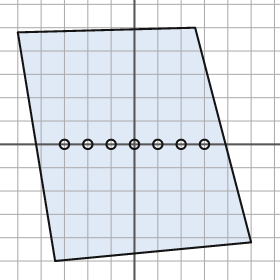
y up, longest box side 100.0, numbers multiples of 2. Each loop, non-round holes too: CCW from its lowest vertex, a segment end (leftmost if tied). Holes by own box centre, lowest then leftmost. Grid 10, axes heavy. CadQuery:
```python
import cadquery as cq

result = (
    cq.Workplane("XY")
    .moveTo(-34.0, -50.0)
    .lineTo(50.0, -42.0)
    .lineTo(26.0, 50.0)
    .lineTo(-50.0, 48.0)
    .close()
    .moveTo(-30.0, 0.0)
    .circle(2.0)
    .moveTo(-20.0, 0.0)
    .circle(2.0)
    .moveTo(-10.0, 0.0)
    .circle(2.0)
    .moveTo(0.0, 0.0)
    .circle(2.0)
    .moveTo(10.0, 0.0)
    .circle(2.0)
    .moveTo(20.0, 0.0)
    .circle(2.0)
    .moveTo(30.0, 0.0)
    .circle(2.0)
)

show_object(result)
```